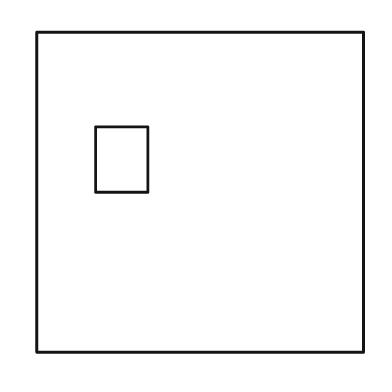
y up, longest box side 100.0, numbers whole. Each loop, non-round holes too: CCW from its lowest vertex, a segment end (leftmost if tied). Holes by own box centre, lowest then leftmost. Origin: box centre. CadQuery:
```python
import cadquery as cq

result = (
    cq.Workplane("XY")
    .moveTo(-50.0, -49.0)
    .lineTo(50.0, -49.0)
    .lineTo(50.0, 49.0)
    .lineTo(-50.0, 49.0)
    .close()
    .moveTo(-32.0, 0.0)
    .lineTo(-16.0, 0.0)
    .lineTo(-16.0, 20.0)
    .lineTo(-32.0, 20.0)
    .close()
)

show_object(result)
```